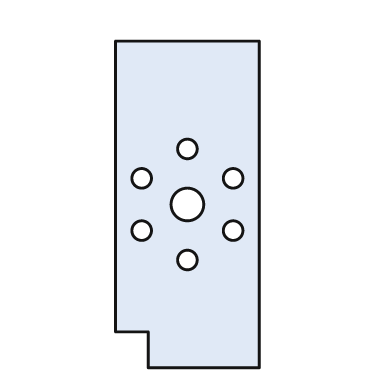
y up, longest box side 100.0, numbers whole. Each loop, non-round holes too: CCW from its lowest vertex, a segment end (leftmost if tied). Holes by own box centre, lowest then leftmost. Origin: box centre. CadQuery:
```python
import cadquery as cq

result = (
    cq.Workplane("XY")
    .moveTo(-12.0, -50.0)
    .lineTo(22.0, -50.0)
    .lineTo(22.0, 50.0)
    .lineTo(-22.0, 50.0)
    .lineTo(-22.0, -39.0)
    .lineTo(-12.0, -39.0)
    .close()
    .moveTo(0.0, -17.0)
    .circle(3.0)
    .moveTo(-14.0, -8.0)
    .circle(3.0)
    .moveTo(14.0, -8.0)
    .circle(3.0)
    .moveTo(0.0, 0.0)
    .circle(5.0)
    .moveTo(-14.0, 8.0)
    .circle(3.0)
    .moveTo(14.0, 8.0)
    .circle(3.0)
    .moveTo(0.0, 17.0)
    .circle(3.0)
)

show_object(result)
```